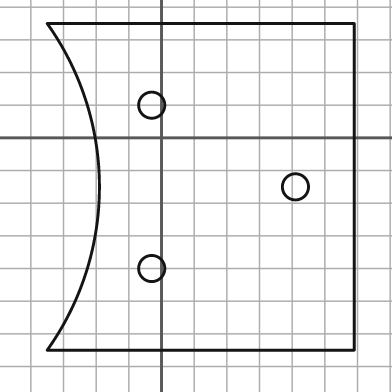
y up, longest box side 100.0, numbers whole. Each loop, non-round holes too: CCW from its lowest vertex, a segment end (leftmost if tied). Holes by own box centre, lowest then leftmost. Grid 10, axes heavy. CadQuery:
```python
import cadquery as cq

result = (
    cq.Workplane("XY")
    .moveTo(-35.0, -65.0)
    .lineTo(59.0, -65.0)
    .lineTo(59.0, 35.0)
    .lineTo(-35.0, 35.0)
    .threePointArc((-19.0, -15.0), (-35.0, -65.0))
    .close()
    .moveTo(-3.0, -40.0)
    .circle(4.0)
    .moveTo(41.0, -15.0)
    .circle(4.0)
    .moveTo(-3.0, 10.0)
    .circle(4.0)
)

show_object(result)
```